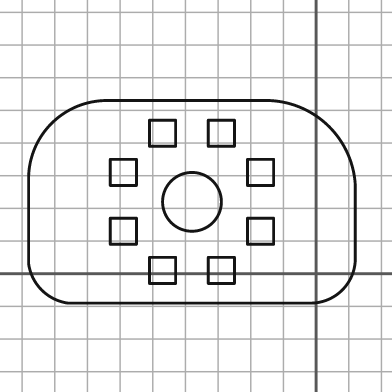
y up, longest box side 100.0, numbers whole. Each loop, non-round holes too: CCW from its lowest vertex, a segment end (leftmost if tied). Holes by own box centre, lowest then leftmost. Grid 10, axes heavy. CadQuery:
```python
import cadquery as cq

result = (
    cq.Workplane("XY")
    .moveTo(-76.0, -9.0)
    .lineTo(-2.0, -9.0)
    .threePointArc((8.0, -5.0), (12.0, 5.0))
    .lineTo(12.0, 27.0)
    .threePointArc((4.0, 45.0), (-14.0, 53.0))
    .lineTo(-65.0, 53.0)
    .threePointArc((-81.0, 46.0), (-88.0, 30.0))
    .lineTo(-88.0, 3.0)
    .threePointArc((-84.0, -5.0), (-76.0, -9.0))
    .close()
    .moveTo(-51.0, -3.0)
    .lineTo(-43.0, -3.0)
    .lineTo(-43.0, 5.0)
    .lineTo(-51.0, 5.0)
    .close()
    .moveTo(-33.0, -3.0)
    .lineTo(-25.0, -3.0)
    .lineTo(-25.0, 5.0)
    .lineTo(-33.0, 5.0)
    .close()
    .moveTo(-63.0, 9.0)
    .lineTo(-55.0, 9.0)
    .lineTo(-55.0, 17.0)
    .lineTo(-63.0, 17.0)
    .close()
    .moveTo(-21.0, 9.0)
    .lineTo(-13.0, 9.0)
    .lineTo(-13.0, 17.0)
    .lineTo(-21.0, 17.0)
    .close()
    .moveTo(-38.0, 22.0)
    .circle(9.0)
    .moveTo(-63.0, 27.0)
    .lineTo(-55.0, 27.0)
    .lineTo(-55.0, 35.0)
    .lineTo(-63.0, 35.0)
    .close()
    .moveTo(-21.0, 27.0)
    .lineTo(-13.0, 27.0)
    .lineTo(-13.0, 35.0)
    .lineTo(-21.0, 35.0)
    .close()
    .moveTo(-51.0, 39.0)
    .lineTo(-43.0, 39.0)
    .lineTo(-43.0, 47.0)
    .lineTo(-51.0, 47.0)
    .close()
    .moveTo(-33.0, 39.0)
    .lineTo(-25.0, 39.0)
    .lineTo(-25.0, 47.0)
    .lineTo(-33.0, 47.0)
    .close()
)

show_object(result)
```